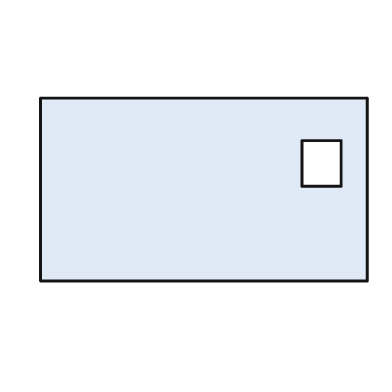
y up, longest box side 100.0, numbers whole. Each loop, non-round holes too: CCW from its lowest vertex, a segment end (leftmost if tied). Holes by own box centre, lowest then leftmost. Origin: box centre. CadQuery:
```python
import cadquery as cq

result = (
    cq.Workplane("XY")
    .moveTo(-50.0, -28.0)
    .lineTo(50.0, -28.0)
    .lineTo(50.0, 28.0)
    .lineTo(-50.0, 28.0)
    .close()
    .moveTo(30.0, 1.0)
    .lineTo(42.0, 1.0)
    .lineTo(42.0, 15.0)
    .lineTo(30.0, 15.0)
    .close()
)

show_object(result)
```